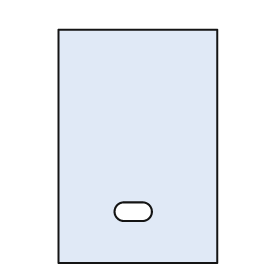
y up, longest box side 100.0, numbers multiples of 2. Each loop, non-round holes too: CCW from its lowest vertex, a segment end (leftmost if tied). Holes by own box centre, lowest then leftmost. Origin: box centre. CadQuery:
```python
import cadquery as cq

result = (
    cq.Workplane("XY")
    .moveTo(-34.0, -50.0)
    .lineTo(34.0, -50.0)
    .lineTo(34.0, 50.0)
    .lineTo(-34.0, 50.0)
    .close()
    .moveTo(-6.0, -32.0)
    .lineTo(2.0, -32.0)
    .threePointArc((6.0, -28.0), (2.0, -24.0))
    .lineTo(-6.0, -24.0)
    .threePointArc((-10.0, -28.0), (-6.0, -32.0))
    .close()
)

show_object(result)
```